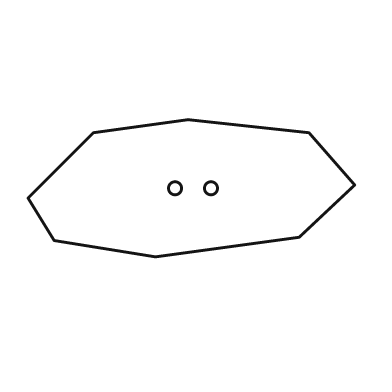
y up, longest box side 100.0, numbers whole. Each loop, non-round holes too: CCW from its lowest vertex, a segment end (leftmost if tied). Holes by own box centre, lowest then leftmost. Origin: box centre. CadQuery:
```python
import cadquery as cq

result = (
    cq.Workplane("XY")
    .moveTo(-11.0, -21.0)
    .lineTo(33.0, -15.0)
    .lineTo(50.0, 1.0)
    .lineTo(36.0, 17.0)
    .lineTo(-1.0, 21.0)
    .lineTo(-30.0, 17.0)
    .lineTo(-50.0, -3.0)
    .lineTo(-42.0, -16.0)
    .close()
    .moveTo(-5.0, 0.0)
    .circle(2.0)
    .moveTo(6.0, 0.0)
    .circle(2.0)
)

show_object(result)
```